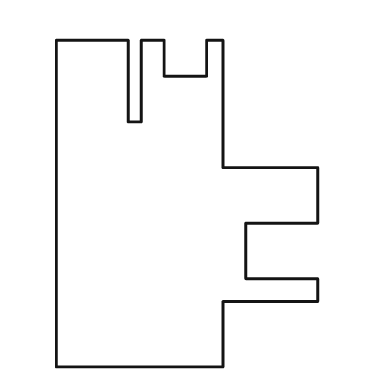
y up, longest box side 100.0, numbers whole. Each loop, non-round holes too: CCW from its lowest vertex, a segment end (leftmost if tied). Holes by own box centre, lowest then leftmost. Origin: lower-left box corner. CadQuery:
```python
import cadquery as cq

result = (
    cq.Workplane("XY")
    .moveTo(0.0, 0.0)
    .lineTo(51.0, 0.0)
    .lineTo(51.0, 20.0)
    .lineTo(80.0, 20.0)
    .lineTo(80.0, 27.0)
    .lineTo(58.0, 27.0)
    .lineTo(58.0, 44.0)
    .lineTo(80.0, 44.0)
    .lineTo(80.0, 61.0)
    .lineTo(51.0, 61.0)
    .lineTo(51.0, 100.0)
    .lineTo(46.0, 100.0)
    .lineTo(46.0, 89.0)
    .lineTo(33.0, 89.0)
    .lineTo(33.0, 100.0)
    .lineTo(26.0, 100.0)
    .lineTo(26.0, 75.0)
    .lineTo(22.0, 75.0)
    .lineTo(22.0, 100.0)
    .lineTo(0.0, 100.0)
    .close()
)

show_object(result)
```